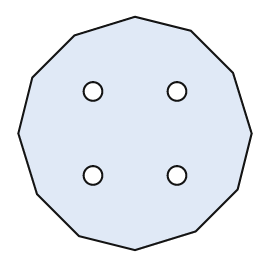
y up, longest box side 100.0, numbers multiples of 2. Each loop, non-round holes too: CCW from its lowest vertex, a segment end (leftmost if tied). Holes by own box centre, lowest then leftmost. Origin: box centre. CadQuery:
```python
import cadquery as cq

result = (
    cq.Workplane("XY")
    .moveTo(0.0, -50.0)
    .lineTo(26.0, -42.0)
    .lineTo(44.0, -24.0)
    .lineTo(50.0, 0.0)
    .lineTo(42.0, 26.0)
    .lineTo(24.0, 44.0)
    .lineTo(0.0, 50.0)
    .lineTo(-26.0, 42.0)
    .lineTo(-44.0, 24.0)
    .lineTo(-50.0, 0.0)
    .lineTo(-42.0, -26.0)
    .lineTo(-24.0, -44.0)
    .close()
    .moveTo(-18.0, -18.0)
    .circle(4.0)
    .moveTo(18.0, -18.0)
    .circle(4.0)
    .moveTo(-18.0, 18.0)
    .circle(4.0)
    .moveTo(18.0, 18.0)
    .circle(4.0)
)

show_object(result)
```